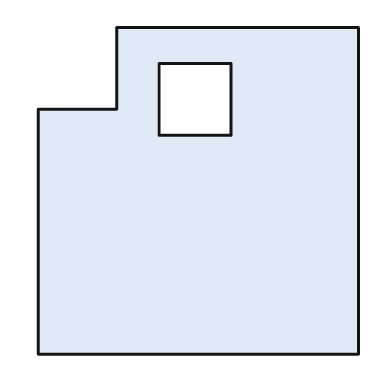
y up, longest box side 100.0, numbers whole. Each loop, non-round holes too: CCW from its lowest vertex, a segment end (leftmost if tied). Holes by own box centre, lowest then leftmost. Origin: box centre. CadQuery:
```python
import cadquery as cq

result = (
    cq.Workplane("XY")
    .moveTo(-49.0, -50.0)
    .lineTo(49.0, -50.0)
    .lineTo(49.0, 50.0)
    .lineTo(-25.0, 50.0)
    .lineTo(-25.0, 25.0)
    .lineTo(-49.0, 25.0)
    .close()
    .moveTo(-12.0, 17.0)
    .lineTo(10.0, 17.0)
    .lineTo(10.0, 39.0)
    .lineTo(-12.0, 39.0)
    .close()
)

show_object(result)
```